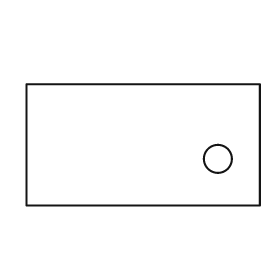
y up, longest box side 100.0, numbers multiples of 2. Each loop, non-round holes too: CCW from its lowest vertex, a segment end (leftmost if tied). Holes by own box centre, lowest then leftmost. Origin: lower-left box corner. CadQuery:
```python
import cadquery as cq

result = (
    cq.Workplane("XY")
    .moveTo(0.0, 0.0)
    .lineTo(100.0, 0.0)
    .lineTo(100.0, 52.0)
    .lineTo(0.0, 52.0)
    .close()
    .moveTo(82.0, 20.0)
    .circle(6.0)
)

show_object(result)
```